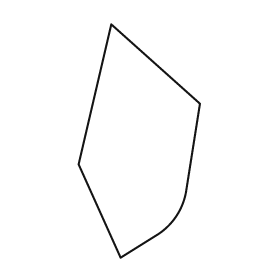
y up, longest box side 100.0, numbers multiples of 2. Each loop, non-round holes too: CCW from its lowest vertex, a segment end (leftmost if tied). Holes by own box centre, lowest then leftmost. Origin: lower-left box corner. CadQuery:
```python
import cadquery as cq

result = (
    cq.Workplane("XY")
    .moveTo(18.0, 0.0)
    .lineTo(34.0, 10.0)
    .threePointArc((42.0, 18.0), (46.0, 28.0))
    .lineTo(52.0, 66.0)
    .lineTo(14.0, 100.0)
    .lineTo(0.0, 40.0)
    .close()
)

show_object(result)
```